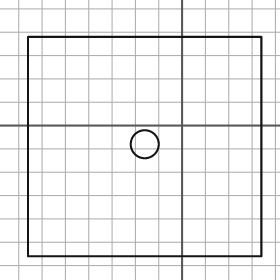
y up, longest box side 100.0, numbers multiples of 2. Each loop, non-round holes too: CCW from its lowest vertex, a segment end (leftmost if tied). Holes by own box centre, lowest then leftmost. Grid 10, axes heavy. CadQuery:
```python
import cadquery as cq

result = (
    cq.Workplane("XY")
    .moveTo(-66.0, -56.0)
    .lineTo(34.0, -56.0)
    .lineTo(34.0, 38.0)
    .lineTo(-66.0, 38.0)
    .close()
    .moveTo(-16.0, -8.0)
    .circle(6.0)
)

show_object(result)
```